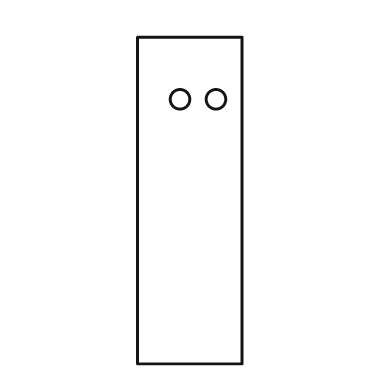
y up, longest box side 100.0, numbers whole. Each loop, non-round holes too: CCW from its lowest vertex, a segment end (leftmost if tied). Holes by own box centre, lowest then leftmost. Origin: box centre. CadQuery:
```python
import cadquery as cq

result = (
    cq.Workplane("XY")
    .moveTo(-16.0, -50.0)
    .lineTo(16.0, -50.0)
    .lineTo(16.0, 50.0)
    .lineTo(-16.0, 50.0)
    .close()
    .moveTo(-3.0, 31.0)
    .circle(3.0)
    .moveTo(8.0, 31.0)
    .circle(3.0)
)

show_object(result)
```